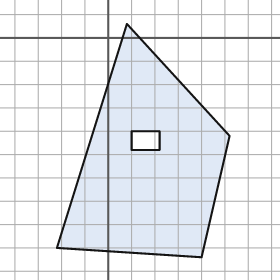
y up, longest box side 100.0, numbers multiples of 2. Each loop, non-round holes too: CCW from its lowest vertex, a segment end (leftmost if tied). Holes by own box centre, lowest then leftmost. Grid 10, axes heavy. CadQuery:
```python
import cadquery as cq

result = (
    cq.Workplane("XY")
    .moveTo(40.0, -94.0)
    .lineTo(52.0, -42.0)
    .lineTo(8.0, 6.0)
    .lineTo(-22.0, -90.0)
    .close()
    .moveTo(10.0, -48.0)
    .lineTo(22.0, -48.0)
    .lineTo(22.0, -40.0)
    .lineTo(10.0, -40.0)
    .close()
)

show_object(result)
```